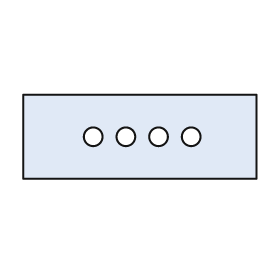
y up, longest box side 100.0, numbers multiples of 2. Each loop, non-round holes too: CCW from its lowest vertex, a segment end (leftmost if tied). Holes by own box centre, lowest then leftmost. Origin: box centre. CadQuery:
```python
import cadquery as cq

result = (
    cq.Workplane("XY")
    .moveTo(-50.0, -18.0)
    .lineTo(50.0, -18.0)
    .lineTo(50.0, 18.0)
    .lineTo(-50.0, 18.0)
    .close()
    .moveTo(-20.0, 0.0)
    .circle(4.0)
    .moveTo(-6.0, 0.0)
    .circle(4.0)
    .moveTo(8.0, 0.0)
    .circle(4.0)
    .moveTo(22.0, 0.0)
    .circle(4.0)
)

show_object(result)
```